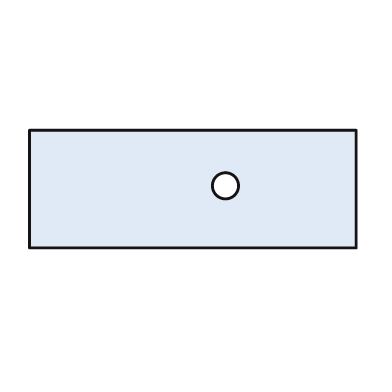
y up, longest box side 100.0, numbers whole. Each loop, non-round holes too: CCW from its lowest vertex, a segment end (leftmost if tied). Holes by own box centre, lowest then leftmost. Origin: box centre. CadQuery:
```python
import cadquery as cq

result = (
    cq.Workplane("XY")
    .moveTo(-50.0, -18.0)
    .lineTo(50.0, -18.0)
    .lineTo(50.0, 18.0)
    .lineTo(-50.0, 18.0)
    .close()
    .moveTo(10.0, 1.0)
    .circle(4.0)
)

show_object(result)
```